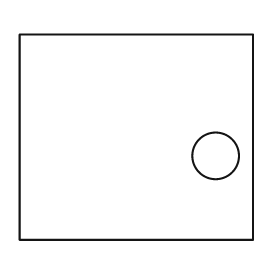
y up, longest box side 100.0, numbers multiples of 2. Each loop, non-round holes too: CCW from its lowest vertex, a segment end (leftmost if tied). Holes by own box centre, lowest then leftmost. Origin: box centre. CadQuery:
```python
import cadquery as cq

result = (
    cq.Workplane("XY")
    .moveTo(-50.0, -44.0)
    .lineTo(50.0, -44.0)
    .lineTo(50.0, 44.0)
    .lineTo(-50.0, 44.0)
    .close()
    .moveTo(34.0, -8.0)
    .circle(10.0)
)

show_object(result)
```